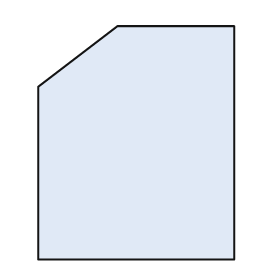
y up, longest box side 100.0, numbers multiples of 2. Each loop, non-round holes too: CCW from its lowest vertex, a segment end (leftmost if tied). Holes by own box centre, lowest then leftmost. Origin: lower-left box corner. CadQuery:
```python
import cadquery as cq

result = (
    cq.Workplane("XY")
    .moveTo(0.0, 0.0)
    .lineTo(84.0, 0.0)
    .lineTo(84.0, 100.0)
    .lineTo(34.0, 100.0)
    .lineTo(0.0, 74.0)
    .close()
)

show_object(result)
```